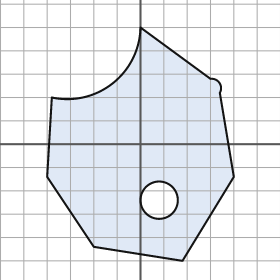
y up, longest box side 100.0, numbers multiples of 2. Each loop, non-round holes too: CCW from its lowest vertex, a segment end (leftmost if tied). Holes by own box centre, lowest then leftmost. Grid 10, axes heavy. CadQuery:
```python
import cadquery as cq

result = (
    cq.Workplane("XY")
    .moveTo(18.0, -50.0)
    .lineTo(40.0, -14.0)
    .lineTo(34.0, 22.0)
    .threePointArc((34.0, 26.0), (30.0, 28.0))
    .lineTo(0.0, 50.0)
    .threePointArc((-12.0, 26.0), (-38.0, 20.0))
    .lineTo(-40.0, -14.0)
    .lineTo(-20.0, -44.0)
    .close()
    .moveTo(8.0, -24.0)
    .circle(8.0)
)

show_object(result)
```